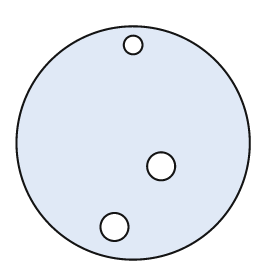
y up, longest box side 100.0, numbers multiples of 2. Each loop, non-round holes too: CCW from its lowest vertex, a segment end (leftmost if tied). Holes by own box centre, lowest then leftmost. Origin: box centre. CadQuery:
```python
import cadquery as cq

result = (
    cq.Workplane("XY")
    .moveTo(0.0, 0.0)
    .circle(50.0)
    .moveTo(-8.0, -36.0)
    .circle(6.0)
    .moveTo(12.0, -10.0)
    .circle(6.0)
    .moveTo(0.0, 42.0)
    .circle(4.0)
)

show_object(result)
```